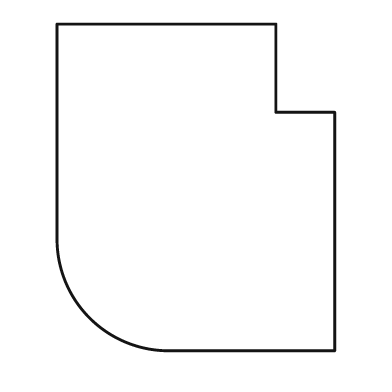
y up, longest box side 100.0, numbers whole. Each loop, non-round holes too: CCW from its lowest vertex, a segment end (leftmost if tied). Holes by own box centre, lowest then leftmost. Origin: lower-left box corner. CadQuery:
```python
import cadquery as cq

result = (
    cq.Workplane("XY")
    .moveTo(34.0, 0.0)
    .lineTo(85.0, 0.0)
    .lineTo(85.0, 73.0)
    .lineTo(67.0, 73.0)
    .lineTo(67.0, 100.0)
    .lineTo(0.0, 100.0)
    .lineTo(0.0, 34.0)
    .threePointArc((10.0, 10.0), (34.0, 0.0))
    .close()
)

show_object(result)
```